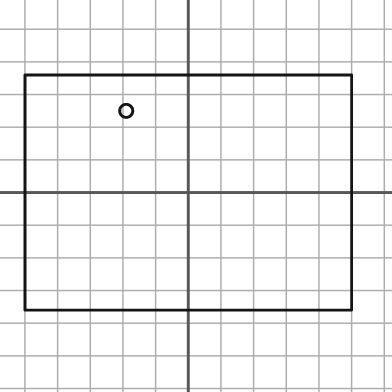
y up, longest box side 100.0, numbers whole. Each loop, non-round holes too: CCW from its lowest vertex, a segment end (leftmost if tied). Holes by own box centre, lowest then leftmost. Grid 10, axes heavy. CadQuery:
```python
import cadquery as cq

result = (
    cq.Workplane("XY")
    .moveTo(-50.0, -36.0)
    .lineTo(50.0, -36.0)
    .lineTo(50.0, 36.0)
    .lineTo(-50.0, 36.0)
    .close()
    .moveTo(-19.0, 25.0)
    .circle(2.0)
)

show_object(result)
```